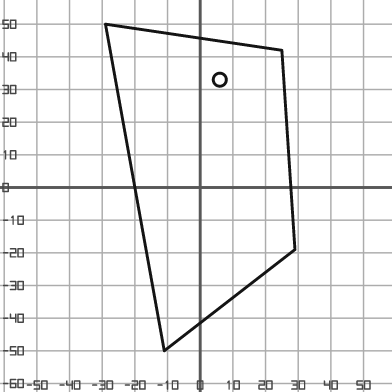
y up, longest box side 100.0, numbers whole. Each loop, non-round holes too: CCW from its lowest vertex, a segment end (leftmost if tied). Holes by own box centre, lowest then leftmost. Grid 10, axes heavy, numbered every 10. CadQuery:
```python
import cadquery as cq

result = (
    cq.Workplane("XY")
    .moveTo(-11.0, -50.0)
    .lineTo(29.0, -19.0)
    .lineTo(25.0, 42.0)
    .lineTo(-29.0, 50.0)
    .close()
    .moveTo(6.0, 33.0)
    .circle(2.0)
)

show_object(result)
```